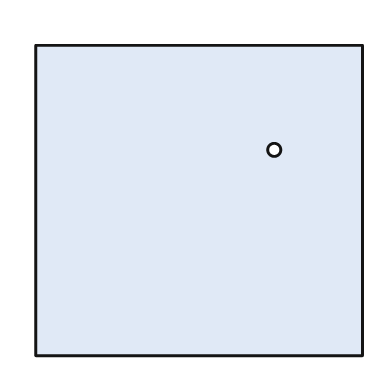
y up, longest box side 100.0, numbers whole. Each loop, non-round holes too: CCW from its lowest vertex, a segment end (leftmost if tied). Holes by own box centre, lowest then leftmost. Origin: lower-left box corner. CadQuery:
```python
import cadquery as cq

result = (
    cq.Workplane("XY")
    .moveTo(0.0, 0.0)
    .lineTo(100.0, 0.0)
    .lineTo(100.0, 95.0)
    .lineTo(0.0, 95.0)
    .close()
    .moveTo(73.0, 63.0)
    .circle(2.0)
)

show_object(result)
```